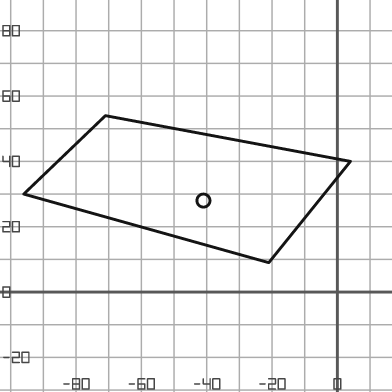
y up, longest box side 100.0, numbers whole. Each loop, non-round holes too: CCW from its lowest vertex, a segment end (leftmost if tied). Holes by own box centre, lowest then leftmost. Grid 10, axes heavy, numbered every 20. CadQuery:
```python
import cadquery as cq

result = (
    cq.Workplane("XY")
    .moveTo(-21.0, 9.0)
    .lineTo(4.0, 40.0)
    .lineTo(-71.0, 54.0)
    .lineTo(-96.0, 30.0)
    .close()
    .moveTo(-41.0, 28.0)
    .circle(2.0)
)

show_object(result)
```